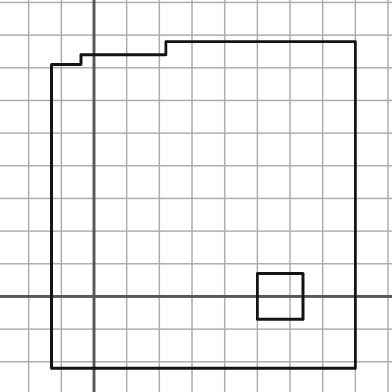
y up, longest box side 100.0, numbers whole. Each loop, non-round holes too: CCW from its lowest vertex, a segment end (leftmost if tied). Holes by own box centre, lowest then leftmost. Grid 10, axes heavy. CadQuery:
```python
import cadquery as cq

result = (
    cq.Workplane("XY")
    .moveTo(-13.0, -22.0)
    .lineTo(80.0, -22.0)
    .lineTo(80.0, 78.0)
    .lineTo(22.0, 78.0)
    .lineTo(22.0, 74.0)
    .lineTo(-4.0, 74.0)
    .lineTo(-4.0, 71.0)
    .lineTo(-13.0, 71.0)
    .close()
    .moveTo(50.0, -7.0)
    .lineTo(64.0, -7.0)
    .lineTo(64.0, 7.0)
    .lineTo(50.0, 7.0)
    .close()
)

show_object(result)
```